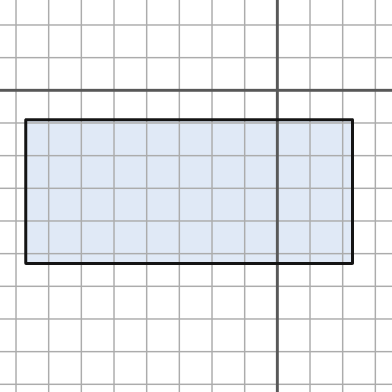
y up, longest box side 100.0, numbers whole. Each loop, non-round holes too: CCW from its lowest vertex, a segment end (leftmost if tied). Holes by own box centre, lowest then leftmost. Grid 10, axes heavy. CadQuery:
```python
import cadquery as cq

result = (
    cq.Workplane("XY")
    .moveTo(-77.0, -53.0)
    .lineTo(23.0, -53.0)
    .lineTo(23.0, -9.0)
    .lineTo(-77.0, -9.0)
    .close()
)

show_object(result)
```